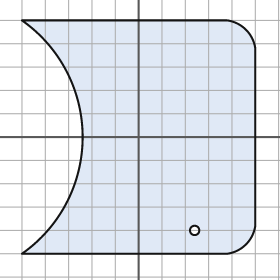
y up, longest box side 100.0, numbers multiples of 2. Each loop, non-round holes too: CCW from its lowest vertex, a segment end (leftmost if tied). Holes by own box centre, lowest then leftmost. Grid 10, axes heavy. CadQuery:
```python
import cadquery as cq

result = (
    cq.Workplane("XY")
    .moveTo(-50.0, -50.0)
    .lineTo(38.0, -50.0)
    .threePointArc((46.0, -46.0), (50.0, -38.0))
    .lineTo(50.0, 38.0)
    .threePointArc((46.0, 46.0), (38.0, 50.0))
    .lineTo(-50.0, 50.0)
    .threePointArc((-24.0, 0.0), (-50.0, -50.0))
    .close()
    .moveTo(24.0, -40.0)
    .circle(2.0)
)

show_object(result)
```